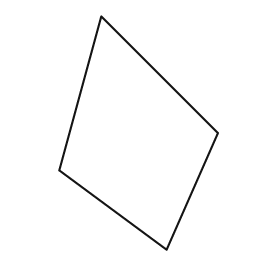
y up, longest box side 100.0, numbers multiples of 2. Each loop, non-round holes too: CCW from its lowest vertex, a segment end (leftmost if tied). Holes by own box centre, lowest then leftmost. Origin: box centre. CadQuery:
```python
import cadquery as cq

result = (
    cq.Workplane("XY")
    .moveTo(12.0, -50.0)
    .lineTo(34.0, 0.0)
    .lineTo(-16.0, 50.0)
    .lineTo(-34.0, -16.0)
    .close()
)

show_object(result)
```